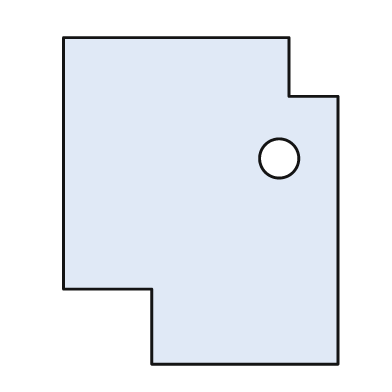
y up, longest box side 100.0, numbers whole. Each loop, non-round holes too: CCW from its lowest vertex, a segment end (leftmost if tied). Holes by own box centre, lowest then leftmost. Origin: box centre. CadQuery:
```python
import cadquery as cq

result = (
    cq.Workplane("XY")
    .moveTo(-15.0, -50.0)
    .lineTo(42.0, -50.0)
    .lineTo(42.0, 32.0)
    .lineTo(27.0, 32.0)
    .lineTo(27.0, 50.0)
    .lineTo(-42.0, 50.0)
    .lineTo(-42.0, -27.0)
    .lineTo(-15.0, -27.0)
    .close()
    .moveTo(24.0, 13.0)
    .circle(6.0)
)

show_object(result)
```